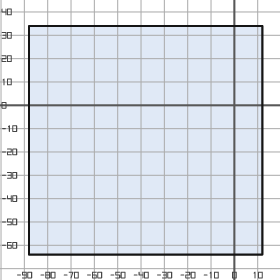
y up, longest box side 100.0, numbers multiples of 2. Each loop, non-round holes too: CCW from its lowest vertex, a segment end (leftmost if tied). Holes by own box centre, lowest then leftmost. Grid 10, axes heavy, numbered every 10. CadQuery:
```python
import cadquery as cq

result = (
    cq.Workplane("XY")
    .moveTo(-88.0, -64.0)
    .lineTo(12.0, -64.0)
    .lineTo(12.0, 34.0)
    .lineTo(-88.0, 34.0)
    .close()
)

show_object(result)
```